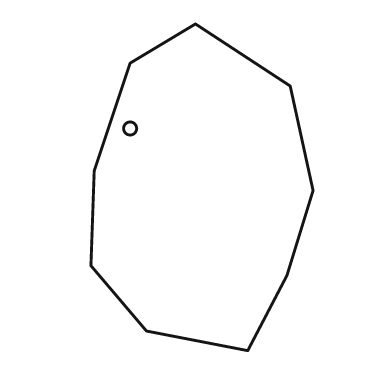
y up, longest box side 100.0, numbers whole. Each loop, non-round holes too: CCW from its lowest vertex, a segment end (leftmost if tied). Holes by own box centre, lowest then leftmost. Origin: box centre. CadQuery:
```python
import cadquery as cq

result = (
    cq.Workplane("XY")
    .moveTo(14.0, -50.0)
    .lineTo(26.0, -27.0)
    .lineTo(34.0, -1.0)
    .lineTo(27.0, 31.0)
    .lineTo(-2.0, 50.0)
    .lineTo(-22.0, 38.0)
    .lineTo(-33.0, 5.0)
    .lineTo(-34.0, -24.0)
    .lineTo(-17.0, -44.0)
    .close()
    .moveTo(-22.0, 18.0)
    .circle(2.0)
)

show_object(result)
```